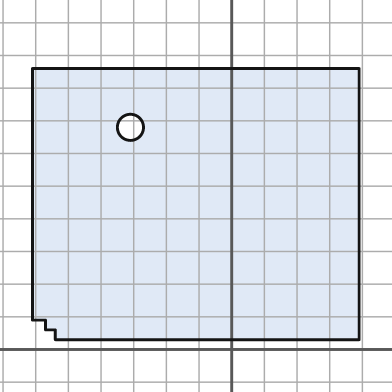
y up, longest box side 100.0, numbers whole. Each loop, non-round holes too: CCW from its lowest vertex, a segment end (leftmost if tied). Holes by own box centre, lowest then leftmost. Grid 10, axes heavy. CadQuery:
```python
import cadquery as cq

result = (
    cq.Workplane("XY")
    .moveTo(-54.0, 3.0)
    .lineTo(39.0, 3.0)
    .lineTo(39.0, 86.0)
    .lineTo(-61.0, 86.0)
    .lineTo(-61.0, 9.0)
    .lineTo(-57.0, 9.0)
    .lineTo(-57.0, 6.0)
    .lineTo(-54.0, 6.0)
    .close()
    .moveTo(-31.0, 68.0)
    .circle(4.0)
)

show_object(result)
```